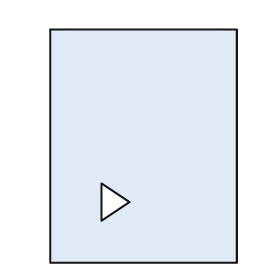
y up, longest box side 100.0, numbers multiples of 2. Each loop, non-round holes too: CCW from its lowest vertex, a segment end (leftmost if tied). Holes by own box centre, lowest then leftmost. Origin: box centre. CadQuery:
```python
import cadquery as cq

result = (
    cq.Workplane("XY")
    .moveTo(-40.0, -50.0)
    .lineTo(40.0, -50.0)
    .lineTo(40.0, 50.0)
    .lineTo(-40.0, 50.0)
    .close()
    .moveTo(-18.0, -32.0)
    .lineTo(-6.0, -24.0)
    .lineTo(-18.0, -16.0)
    .close()
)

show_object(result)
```